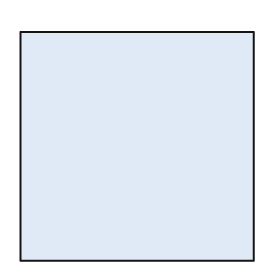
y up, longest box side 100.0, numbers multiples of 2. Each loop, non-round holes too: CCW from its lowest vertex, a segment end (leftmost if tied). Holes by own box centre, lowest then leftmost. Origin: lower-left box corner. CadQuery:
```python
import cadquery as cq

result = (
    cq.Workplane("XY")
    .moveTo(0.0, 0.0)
    .lineTo(100.0, 0.0)
    .lineTo(100.0, 98.0)
    .lineTo(0.0, 98.0)
    .close()
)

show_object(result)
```